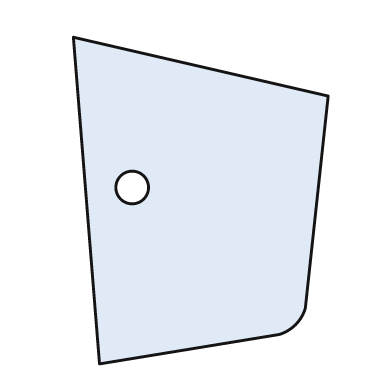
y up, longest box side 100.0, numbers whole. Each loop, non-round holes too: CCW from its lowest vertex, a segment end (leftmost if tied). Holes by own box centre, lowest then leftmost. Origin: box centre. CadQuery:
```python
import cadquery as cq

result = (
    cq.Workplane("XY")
    .moveTo(-31.0, -50.0)
    .lineTo(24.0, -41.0)
    .threePointArc((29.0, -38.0), (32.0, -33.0))
    .lineTo(39.0, 32.0)
    .lineTo(-39.0, 50.0)
    .close()
    .moveTo(-21.0, 4.0)
    .circle(5.0)
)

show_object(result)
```